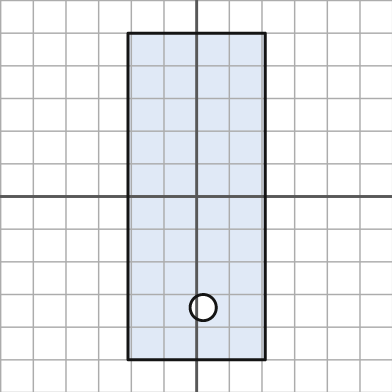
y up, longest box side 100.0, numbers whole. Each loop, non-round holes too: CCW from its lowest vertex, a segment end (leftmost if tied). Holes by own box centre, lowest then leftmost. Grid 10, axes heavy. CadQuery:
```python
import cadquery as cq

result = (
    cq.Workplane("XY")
    .moveTo(-21.0, -50.0)
    .lineTo(21.0, -50.0)
    .lineTo(21.0, 50.0)
    .lineTo(-21.0, 50.0)
    .close()
    .moveTo(2.0, -34.0)
    .circle(4.0)
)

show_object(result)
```